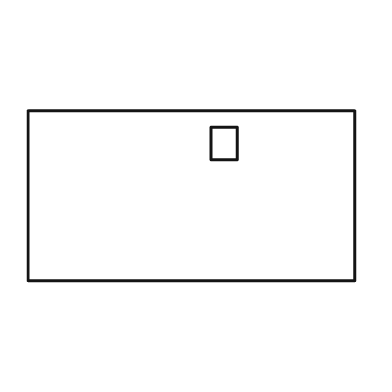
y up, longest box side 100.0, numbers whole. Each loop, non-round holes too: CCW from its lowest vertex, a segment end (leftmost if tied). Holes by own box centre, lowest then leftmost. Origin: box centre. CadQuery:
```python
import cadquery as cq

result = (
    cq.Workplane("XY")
    .moveTo(-50.0, -26.0)
    .lineTo(50.0, -26.0)
    .lineTo(50.0, 26.0)
    .lineTo(-50.0, 26.0)
    .close()
    .moveTo(6.0, 11.0)
    .lineTo(14.0, 11.0)
    .lineTo(14.0, 21.0)
    .lineTo(6.0, 21.0)
    .close()
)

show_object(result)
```